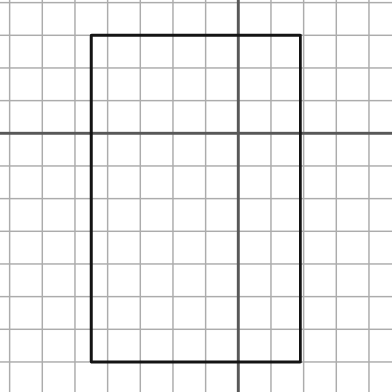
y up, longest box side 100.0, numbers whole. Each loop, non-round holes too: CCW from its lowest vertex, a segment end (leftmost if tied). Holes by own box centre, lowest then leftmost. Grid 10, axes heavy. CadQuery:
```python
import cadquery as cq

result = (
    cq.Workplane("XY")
    .moveTo(-45.0, -70.0)
    .lineTo(19.0, -70.0)
    .lineTo(19.0, 30.0)
    .lineTo(-45.0, 30.0)
    .close()
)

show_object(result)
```